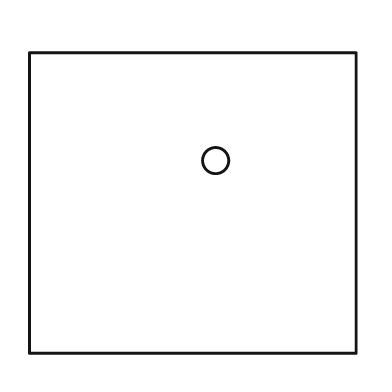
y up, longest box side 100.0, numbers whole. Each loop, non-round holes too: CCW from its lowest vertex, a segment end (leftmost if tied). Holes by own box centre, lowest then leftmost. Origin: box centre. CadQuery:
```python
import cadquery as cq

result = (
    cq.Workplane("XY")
    .moveTo(-50.0, -46.0)
    .lineTo(50.0, -46.0)
    .lineTo(50.0, 46.0)
    .lineTo(-50.0, 46.0)
    .close()
    .moveTo(7.0, 13.0)
    .circle(4.0)
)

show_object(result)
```